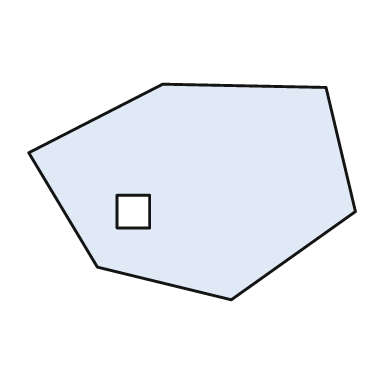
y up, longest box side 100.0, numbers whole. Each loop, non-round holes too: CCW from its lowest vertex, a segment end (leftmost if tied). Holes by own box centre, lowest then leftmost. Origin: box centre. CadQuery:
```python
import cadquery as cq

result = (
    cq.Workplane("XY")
    .moveTo(12.0, -33.0)
    .lineTo(50.0, -6.0)
    .lineTo(41.0, 32.0)
    .lineTo(-9.0, 33.0)
    .lineTo(-50.0, 12.0)
    .lineTo(-29.0, -23.0)
    .close()
    .moveTo(-23.0, -11.0)
    .lineTo(-13.0, -11.0)
    .lineTo(-13.0, -1.0)
    .lineTo(-23.0, -1.0)
    .close()
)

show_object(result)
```